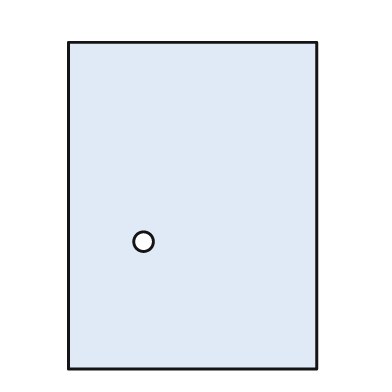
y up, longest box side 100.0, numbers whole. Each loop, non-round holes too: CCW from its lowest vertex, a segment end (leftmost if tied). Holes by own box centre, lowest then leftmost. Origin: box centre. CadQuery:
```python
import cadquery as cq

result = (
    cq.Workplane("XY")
    .moveTo(-38.0, -50.0)
    .lineTo(38.0, -50.0)
    .lineTo(38.0, 50.0)
    .lineTo(-38.0, 50.0)
    .close()
    .moveTo(-15.0, -11.0)
    .circle(3.0)
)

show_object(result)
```